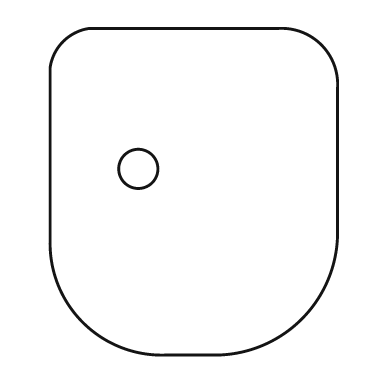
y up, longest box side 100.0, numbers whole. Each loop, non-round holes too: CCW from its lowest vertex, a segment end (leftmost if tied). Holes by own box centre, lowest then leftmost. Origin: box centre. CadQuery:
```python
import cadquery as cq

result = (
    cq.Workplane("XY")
    .moveTo(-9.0, -50.0)
    .lineTo(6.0, -50.0)
    .threePointArc((33.0, -39.0), (44.0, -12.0))
    .lineTo(44.0, 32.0)
    .threePointArc((39.0, 45.0), (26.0, 50.0))
    .lineTo(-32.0, 50.0)
    .threePointArc((-40.0, 46.0), (-44.0, 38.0))
    .lineTo(-44.0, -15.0)
    .threePointArc((-34.0, -40.0), (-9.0, -50.0))
    .close()
    .moveTo(-17.0, 7.0)
    .circle(6.0)
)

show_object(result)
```